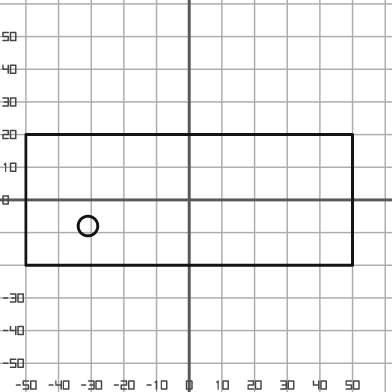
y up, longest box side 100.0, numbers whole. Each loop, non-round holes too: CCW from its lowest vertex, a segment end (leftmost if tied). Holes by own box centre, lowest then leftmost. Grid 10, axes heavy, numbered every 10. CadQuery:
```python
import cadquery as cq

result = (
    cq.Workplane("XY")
    .moveTo(-50.0, -20.0)
    .lineTo(50.0, -20.0)
    .lineTo(50.0, 20.0)
    .lineTo(-50.0, 20.0)
    .close()
    .moveTo(-31.0, -8.0)
    .circle(3.0)
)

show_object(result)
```